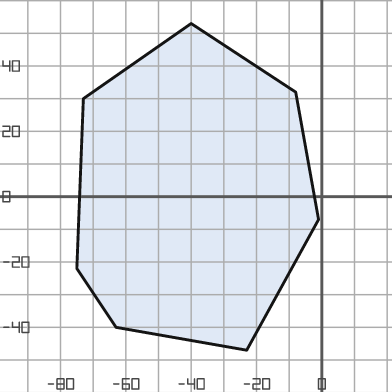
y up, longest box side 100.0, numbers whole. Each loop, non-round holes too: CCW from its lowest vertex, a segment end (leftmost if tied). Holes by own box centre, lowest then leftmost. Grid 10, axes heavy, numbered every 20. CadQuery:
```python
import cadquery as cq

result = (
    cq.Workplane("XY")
    .moveTo(-23.0, -47.0)
    .lineTo(-1.0, -7.0)
    .lineTo(-8.0, 32.0)
    .lineTo(-40.0, 53.0)
    .lineTo(-73.0, 30.0)
    .lineTo(-75.0, -22.0)
    .lineTo(-63.0, -40.0)
    .close()
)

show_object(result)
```